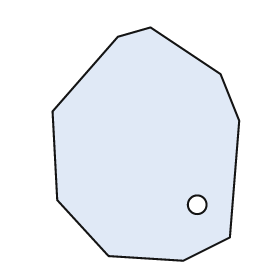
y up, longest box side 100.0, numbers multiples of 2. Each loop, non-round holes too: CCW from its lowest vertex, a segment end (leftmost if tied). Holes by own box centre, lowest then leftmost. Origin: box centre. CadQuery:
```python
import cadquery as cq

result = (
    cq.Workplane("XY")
    .moveTo(16.0, -50.0)
    .lineTo(36.0, -40.0)
    .lineTo(40.0, 10.0)
    .lineTo(32.0, 30.0)
    .lineTo(2.0, 50.0)
    .lineTo(-12.0, 46.0)
    .lineTo(-40.0, 14.0)
    .lineTo(-38.0, -24.0)
    .lineTo(-16.0, -48.0)
    .close()
    .moveTo(22.0, -26.0)
    .circle(4.0)
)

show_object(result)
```